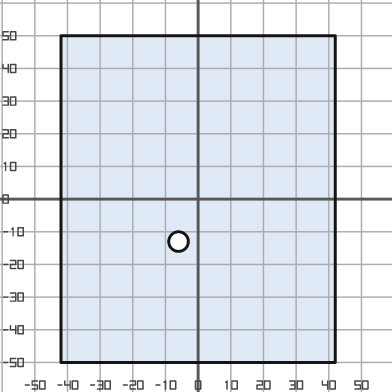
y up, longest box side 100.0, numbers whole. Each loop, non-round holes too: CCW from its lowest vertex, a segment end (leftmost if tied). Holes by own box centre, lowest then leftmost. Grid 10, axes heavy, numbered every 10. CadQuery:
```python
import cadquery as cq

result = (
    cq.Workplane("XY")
    .moveTo(-42.0, -50.0)
    .lineTo(42.0, -50.0)
    .lineTo(42.0, 50.0)
    .lineTo(-42.0, 50.0)
    .close()
    .moveTo(-6.0, -13.0)
    .circle(3.0)
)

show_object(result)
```